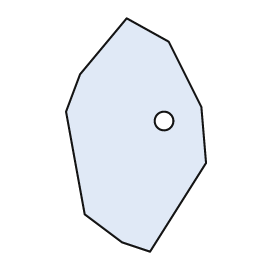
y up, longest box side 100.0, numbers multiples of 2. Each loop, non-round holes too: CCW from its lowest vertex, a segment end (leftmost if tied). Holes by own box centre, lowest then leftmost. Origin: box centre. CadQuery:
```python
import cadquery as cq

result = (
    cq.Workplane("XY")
    .moveTo(6.0, -50.0)
    .lineTo(30.0, -12.0)
    .lineTo(28.0, 12.0)
    .lineTo(14.0, 40.0)
    .lineTo(-4.0, 50.0)
    .lineTo(-24.0, 26.0)
    .lineTo(-30.0, 10.0)
    .lineTo(-22.0, -34.0)
    .lineTo(-6.0, -46.0)
    .close()
    .moveTo(12.0, 6.0)
    .circle(4.0)
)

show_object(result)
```